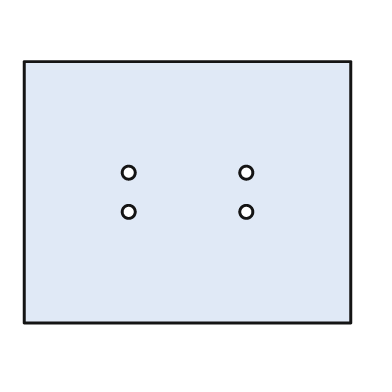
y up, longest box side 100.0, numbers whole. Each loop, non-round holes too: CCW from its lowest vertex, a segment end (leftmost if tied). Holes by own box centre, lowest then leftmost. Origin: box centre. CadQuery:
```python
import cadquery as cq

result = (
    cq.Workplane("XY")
    .moveTo(-50.0, -40.0)
    .lineTo(50.0, -40.0)
    .lineTo(50.0, 40.0)
    .lineTo(-50.0, 40.0)
    .close()
    .moveTo(-18.0, -6.0)
    .circle(2.0)
    .moveTo(18.0, -6.0)
    .circle(2.0)
    .moveTo(-18.0, 6.0)
    .circle(2.0)
    .moveTo(18.0, 6.0)
    .circle(2.0)
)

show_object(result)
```